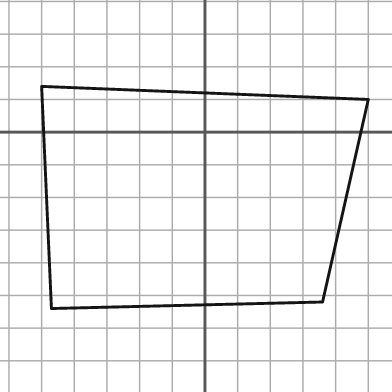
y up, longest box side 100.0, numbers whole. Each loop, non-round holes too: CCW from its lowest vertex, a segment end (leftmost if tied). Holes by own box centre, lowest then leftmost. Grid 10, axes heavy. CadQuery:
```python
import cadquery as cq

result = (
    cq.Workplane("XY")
    .moveTo(-47.0, -54.0)
    .lineTo(36.0, -52.0)
    .lineTo(50.0, 10.0)
    .lineTo(-50.0, 14.0)
    .close()
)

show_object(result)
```